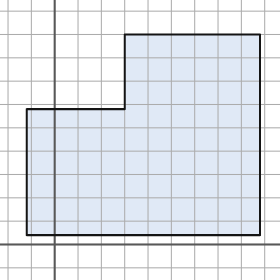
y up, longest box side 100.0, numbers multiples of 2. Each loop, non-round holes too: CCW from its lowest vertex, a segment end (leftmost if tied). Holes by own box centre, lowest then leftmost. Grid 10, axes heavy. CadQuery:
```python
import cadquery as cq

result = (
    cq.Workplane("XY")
    .moveTo(-12.0, 4.0)
    .lineTo(88.0, 4.0)
    .lineTo(88.0, 90.0)
    .lineTo(30.0, 90.0)
    .lineTo(30.0, 58.0)
    .lineTo(-12.0, 58.0)
    .close()
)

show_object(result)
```